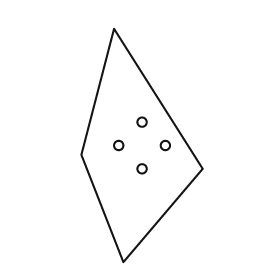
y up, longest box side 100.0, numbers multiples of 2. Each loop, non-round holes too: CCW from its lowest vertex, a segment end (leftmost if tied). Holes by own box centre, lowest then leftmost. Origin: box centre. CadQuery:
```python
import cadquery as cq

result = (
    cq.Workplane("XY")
    .moveTo(-8.0, -50.0)
    .lineTo(26.0, -10.0)
    .lineTo(-12.0, 50.0)
    .lineTo(-26.0, -4.0)
    .close()
    .moveTo(0.0, -10.0)
    .circle(2.0)
    .moveTo(-10.0, 0.0)
    .circle(2.0)
    .moveTo(10.0, 0.0)
    .circle(2.0)
    .moveTo(0.0, 10.0)
    .circle(2.0)
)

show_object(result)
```